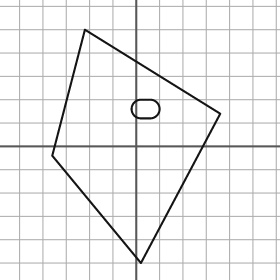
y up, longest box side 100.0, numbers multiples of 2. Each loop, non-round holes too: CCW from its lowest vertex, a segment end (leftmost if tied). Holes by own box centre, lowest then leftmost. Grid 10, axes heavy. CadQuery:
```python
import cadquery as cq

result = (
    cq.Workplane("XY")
    .moveTo(2.0, -50.0)
    .lineTo(36.0, 14.0)
    .lineTo(-22.0, 50.0)
    .lineTo(-36.0, -4.0)
    .close()
    .moveTo(2.0, 12.0)
    .lineTo(6.0, 12.0)
    .threePointArc((10.0, 16.0), (6.0, 20.0))
    .lineTo(2.0, 20.0)
    .threePointArc((-2.0, 16.0), (2.0, 12.0))
    .close()
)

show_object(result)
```